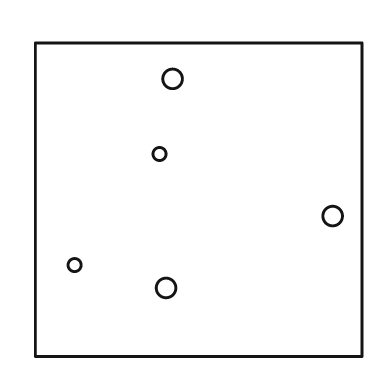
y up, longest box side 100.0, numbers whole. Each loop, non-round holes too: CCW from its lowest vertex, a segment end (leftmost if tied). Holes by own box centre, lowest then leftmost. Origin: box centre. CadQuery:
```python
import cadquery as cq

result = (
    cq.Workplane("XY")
    .moveTo(-50.0, -48.0)
    .lineTo(50.0, -48.0)
    .lineTo(50.0, 48.0)
    .lineTo(-50.0, 48.0)
    .close()
    .moveTo(-10.0, -27.0)
    .circle(3.0)
    .moveTo(-38.0, -20.0)
    .circle(2.0)
    .moveTo(41.0, -5.0)
    .circle(3.0)
    .moveTo(-12.0, 14.0)
    .circle(2.0)
    .moveTo(-8.0, 37.0)
    .circle(3.0)
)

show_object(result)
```